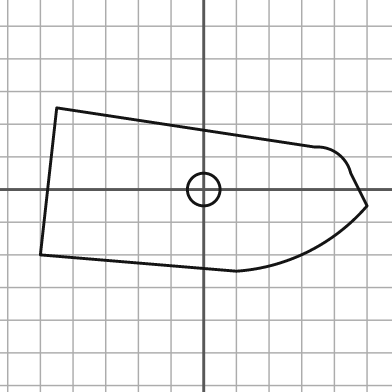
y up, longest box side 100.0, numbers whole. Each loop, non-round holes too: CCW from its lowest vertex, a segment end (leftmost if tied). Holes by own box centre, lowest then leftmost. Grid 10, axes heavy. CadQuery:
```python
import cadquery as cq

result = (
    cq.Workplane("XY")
    .moveTo(10.0, -25.0)
    .threePointArc((32.0, -19.0), (50.0, -5.0))
    .lineTo(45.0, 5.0)
    .threePointArc((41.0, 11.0), (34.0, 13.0))
    .lineTo(-45.0, 25.0)
    .lineTo(-50.0, -20.0)
    .close()
    .moveTo(0.0, 0.0)
    .circle(5.0)
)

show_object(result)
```